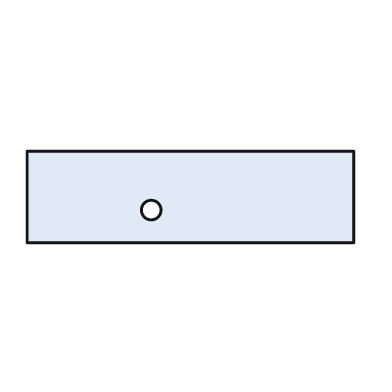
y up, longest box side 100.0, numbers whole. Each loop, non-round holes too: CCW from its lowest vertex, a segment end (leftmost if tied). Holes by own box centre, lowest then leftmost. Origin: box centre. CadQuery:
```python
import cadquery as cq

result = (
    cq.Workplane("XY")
    .moveTo(-50.0, -14.0)
    .lineTo(50.0, -14.0)
    .lineTo(50.0, 14.0)
    .lineTo(-50.0, 14.0)
    .close()
    .moveTo(-12.0, -4.0)
    .circle(3.0)
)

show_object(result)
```